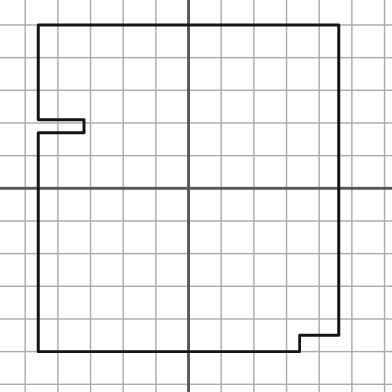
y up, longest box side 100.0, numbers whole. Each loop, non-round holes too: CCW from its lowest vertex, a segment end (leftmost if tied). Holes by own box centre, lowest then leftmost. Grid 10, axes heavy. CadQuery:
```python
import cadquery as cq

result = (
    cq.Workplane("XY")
    .moveTo(-46.0, -50.0)
    .lineTo(34.0, -50.0)
    .lineTo(34.0, -45.0)
    .lineTo(46.0, -45.0)
    .lineTo(46.0, 50.0)
    .lineTo(-46.0, 50.0)
    .lineTo(-46.0, 21.0)
    .lineTo(-32.0, 21.0)
    .lineTo(-32.0, 17.0)
    .lineTo(-46.0, 17.0)
    .close()
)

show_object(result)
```